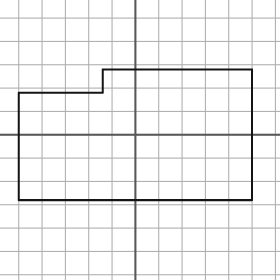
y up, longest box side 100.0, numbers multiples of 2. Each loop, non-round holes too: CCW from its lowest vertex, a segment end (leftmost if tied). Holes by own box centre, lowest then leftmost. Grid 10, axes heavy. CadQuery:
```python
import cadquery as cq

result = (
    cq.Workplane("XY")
    .moveTo(-50.0, -28.0)
    .lineTo(50.0, -28.0)
    .lineTo(50.0, 28.0)
    .lineTo(-14.0, 28.0)
    .lineTo(-14.0, 18.0)
    .lineTo(-50.0, 18.0)
    .close()
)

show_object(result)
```